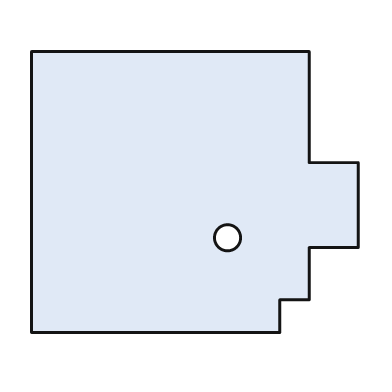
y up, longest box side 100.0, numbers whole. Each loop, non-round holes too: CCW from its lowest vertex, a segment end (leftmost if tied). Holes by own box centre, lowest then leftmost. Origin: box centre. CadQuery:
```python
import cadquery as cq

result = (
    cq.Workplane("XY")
    .moveTo(-50.0, -43.0)
    .lineTo(26.0, -43.0)
    .lineTo(26.0, -33.0)
    .lineTo(35.0, -33.0)
    .lineTo(35.0, -17.0)
    .lineTo(50.0, -17.0)
    .lineTo(50.0, 9.0)
    .lineTo(35.0, 9.0)
    .lineTo(35.0, 43.0)
    .lineTo(-50.0, 43.0)
    .close()
    .moveTo(10.0, -14.0)
    .circle(4.0)
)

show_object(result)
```